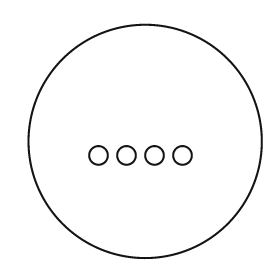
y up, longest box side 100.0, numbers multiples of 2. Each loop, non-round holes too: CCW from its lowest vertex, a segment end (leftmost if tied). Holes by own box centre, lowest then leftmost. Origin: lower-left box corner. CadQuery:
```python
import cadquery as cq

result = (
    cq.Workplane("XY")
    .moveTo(50.0, 50.0)
    .circle(50.0)
    .moveTo(30.0, 44.0)
    .circle(4.0)
    .moveTo(42.0, 44.0)
    .circle(4.0)
    .moveTo(54.0, 44.0)
    .circle(4.0)
    .moveTo(66.0, 44.0)
    .circle(4.0)
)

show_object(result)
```